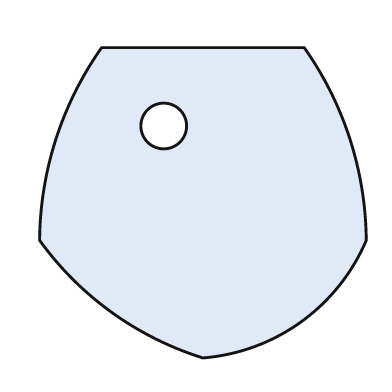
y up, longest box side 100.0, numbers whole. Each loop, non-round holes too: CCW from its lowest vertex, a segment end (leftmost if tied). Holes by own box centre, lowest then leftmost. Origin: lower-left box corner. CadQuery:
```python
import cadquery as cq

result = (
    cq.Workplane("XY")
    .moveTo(50.0, 0.0)
    .threePointArc((80.0, 11.0), (100.0, 36.0))
    .threePointArc((95.0, 67.0), (81.0, 95.0))
    .lineTo(19.0, 95.0)
    .threePointArc((5.0, 67.0), (0.0, 36.0))
    .threePointArc((22.0, 14.0), (50.0, 0.0))
    .close()
    .moveTo(38.0, 71.0)
    .circle(7.0)
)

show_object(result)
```